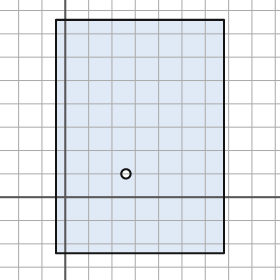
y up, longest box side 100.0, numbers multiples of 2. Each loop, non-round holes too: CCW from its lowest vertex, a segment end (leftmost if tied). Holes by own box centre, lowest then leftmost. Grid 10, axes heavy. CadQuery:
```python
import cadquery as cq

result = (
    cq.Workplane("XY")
    .moveTo(-4.0, -24.0)
    .lineTo(68.0, -24.0)
    .lineTo(68.0, 76.0)
    .lineTo(-4.0, 76.0)
    .close()
    .moveTo(26.0, 10.0)
    .circle(2.0)
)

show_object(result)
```